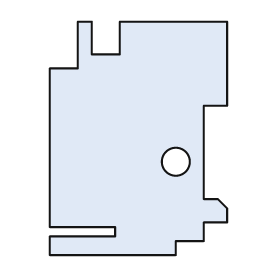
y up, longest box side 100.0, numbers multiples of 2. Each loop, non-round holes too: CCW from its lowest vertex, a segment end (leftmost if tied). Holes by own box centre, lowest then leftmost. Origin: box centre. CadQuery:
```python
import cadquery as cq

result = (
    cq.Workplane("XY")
    .moveTo(-38.0, -50.0)
    .lineTo(16.0, -50.0)
    .lineTo(16.0, -44.0)
    .lineTo(28.0, -44.0)
    .lineTo(28.0, -36.0)
    .lineTo(38.0, -36.0)
    .lineTo(38.0, -30.0)
    .lineTo(34.0, -26.0)
    .lineTo(28.0, -26.0)
    .lineTo(28.0, 14.0)
    .lineTo(38.0, 14.0)
    .lineTo(38.0, 50.0)
    .lineTo(-8.0, 50.0)
    .lineTo(-8.0, 36.0)
    .lineTo(-20.0, 36.0)
    .lineTo(-20.0, 50.0)
    .lineTo(-26.0, 50.0)
    .lineTo(-26.0, 30.0)
    .lineTo(-38.0, 30.0)
    .lineTo(-38.0, -38.0)
    .lineTo(-10.0, -38.0)
    .lineTo(-10.0, -42.0)
    .lineTo(-38.0, -42.0)
    .close()
    .moveTo(16.0, -10.0)
    .circle(6.0)
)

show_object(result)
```